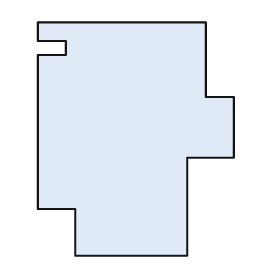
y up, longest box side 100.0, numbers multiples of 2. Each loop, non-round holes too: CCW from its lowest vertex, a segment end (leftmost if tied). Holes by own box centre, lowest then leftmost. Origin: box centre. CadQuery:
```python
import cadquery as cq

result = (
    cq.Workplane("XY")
    .moveTo(-26.0, -50.0)
    .lineTo(22.0, -50.0)
    .lineTo(22.0, -8.0)
    .lineTo(42.0, -8.0)
    .lineTo(42.0, 18.0)
    .lineTo(30.0, 18.0)
    .lineTo(30.0, 50.0)
    .lineTo(-42.0, 50.0)
    .lineTo(-42.0, 42.0)
    .lineTo(-30.0, 42.0)
    .lineTo(-30.0, 36.0)
    .lineTo(-42.0, 36.0)
    .lineTo(-42.0, -30.0)
    .lineTo(-26.0, -30.0)
    .close()
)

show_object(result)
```